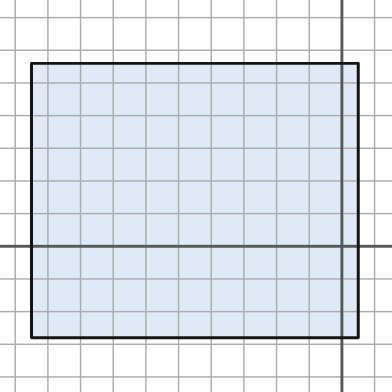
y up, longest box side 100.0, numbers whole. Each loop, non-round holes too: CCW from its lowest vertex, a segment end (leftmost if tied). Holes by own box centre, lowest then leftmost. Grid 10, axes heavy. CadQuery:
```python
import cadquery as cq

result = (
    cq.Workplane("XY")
    .moveTo(-95.0, -28.0)
    .lineTo(5.0, -28.0)
    .lineTo(5.0, 56.0)
    .lineTo(-95.0, 56.0)
    .close()
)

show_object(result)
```